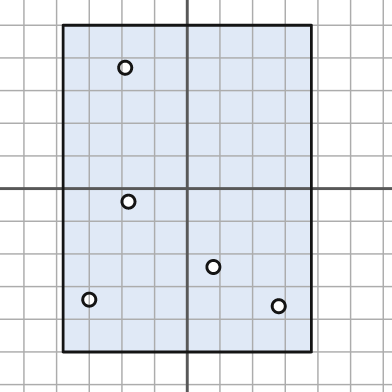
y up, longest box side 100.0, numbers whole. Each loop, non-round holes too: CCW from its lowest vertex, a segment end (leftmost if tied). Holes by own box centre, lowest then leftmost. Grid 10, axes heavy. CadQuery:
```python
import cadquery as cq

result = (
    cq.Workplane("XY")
    .moveTo(-38.0, -50.0)
    .lineTo(38.0, -50.0)
    .lineTo(38.0, 50.0)
    .lineTo(-38.0, 50.0)
    .close()
    .moveTo(28.0, -36.0)
    .circle(2.0)
    .moveTo(-30.0, -34.0)
    .circle(2.0)
    .moveTo(8.0, -24.0)
    .circle(2.0)
    .moveTo(-18.0, -4.0)
    .circle(2.0)
    .moveTo(-19.0, 37.0)
    .circle(2.0)
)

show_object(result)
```